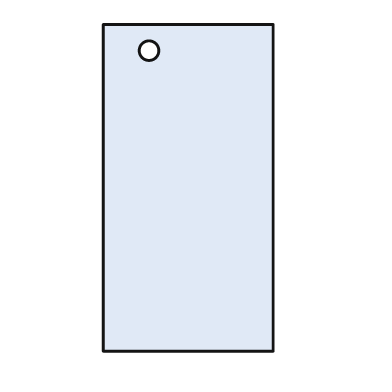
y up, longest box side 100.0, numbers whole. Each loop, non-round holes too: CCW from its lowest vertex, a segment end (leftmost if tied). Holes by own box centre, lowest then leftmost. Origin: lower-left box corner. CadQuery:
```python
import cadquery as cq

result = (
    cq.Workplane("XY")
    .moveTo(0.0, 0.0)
    .lineTo(52.0, 0.0)
    .lineTo(52.0, 100.0)
    .lineTo(0.0, 100.0)
    .close()
    .moveTo(14.0, 92.0)
    .circle(3.0)
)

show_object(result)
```